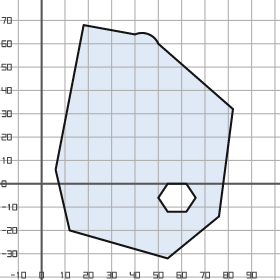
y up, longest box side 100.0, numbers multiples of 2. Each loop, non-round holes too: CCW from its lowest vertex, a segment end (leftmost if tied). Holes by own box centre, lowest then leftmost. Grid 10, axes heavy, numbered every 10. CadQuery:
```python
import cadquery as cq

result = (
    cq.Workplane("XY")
    .moveTo(54.0, -32.0)
    .lineTo(76.0, -14.0)
    .lineTo(82.0, 32.0)
    .lineTo(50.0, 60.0)
    .threePointArc((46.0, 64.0), (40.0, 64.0))
    .lineTo(18.0, 68.0)
    .lineTo(6.0, 6.0)
    .lineTo(12.0, -20.0)
    .close()
    .moveTo(54.0, -12.0)
    .lineTo(62.0, -12.0)
    .lineTo(66.0, -6.0)
    .lineTo(62.0, 0.0)
    .lineTo(54.0, 0.0)
    .lineTo(50.0, -6.0)
    .close()
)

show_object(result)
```